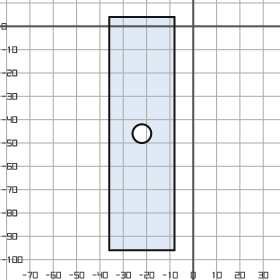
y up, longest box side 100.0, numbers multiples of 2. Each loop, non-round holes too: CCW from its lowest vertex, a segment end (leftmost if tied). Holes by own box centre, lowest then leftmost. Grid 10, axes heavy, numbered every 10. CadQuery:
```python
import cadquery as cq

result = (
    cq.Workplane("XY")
    .moveTo(-36.0, -96.0)
    .lineTo(-8.0, -96.0)
    .lineTo(-8.0, 4.0)
    .lineTo(-36.0, 4.0)
    .close()
    .moveTo(-22.0, -46.0)
    .circle(4.0)
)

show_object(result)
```